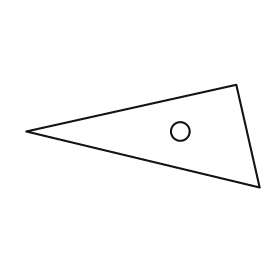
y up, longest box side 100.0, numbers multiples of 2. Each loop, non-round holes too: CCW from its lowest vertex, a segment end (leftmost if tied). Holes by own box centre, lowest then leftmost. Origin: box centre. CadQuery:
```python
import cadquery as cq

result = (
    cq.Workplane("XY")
    .moveTo(50.0, -22.0)
    .lineTo(40.0, 22.0)
    .lineTo(-50.0, 2.0)
    .close()
    .moveTo(16.0, 2.0)
    .circle(4.0)
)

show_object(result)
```